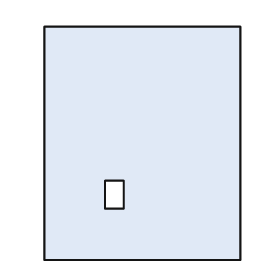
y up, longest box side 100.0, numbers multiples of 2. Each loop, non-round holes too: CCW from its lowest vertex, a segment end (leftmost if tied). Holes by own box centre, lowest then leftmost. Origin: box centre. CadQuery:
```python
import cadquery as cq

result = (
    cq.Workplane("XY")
    .moveTo(-42.0, -50.0)
    .lineTo(42.0, -50.0)
    .lineTo(42.0, 50.0)
    .lineTo(-42.0, 50.0)
    .close()
    .moveTo(-16.0, -28.0)
    .lineTo(-8.0, -28.0)
    .lineTo(-8.0, -16.0)
    .lineTo(-16.0, -16.0)
    .close()
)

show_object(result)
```